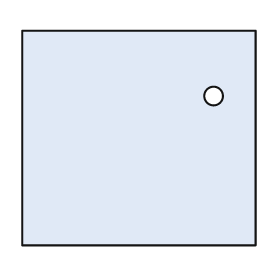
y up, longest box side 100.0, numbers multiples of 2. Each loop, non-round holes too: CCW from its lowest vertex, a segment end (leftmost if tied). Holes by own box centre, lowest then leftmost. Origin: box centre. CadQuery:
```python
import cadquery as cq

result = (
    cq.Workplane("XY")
    .moveTo(-50.0, -46.0)
    .lineTo(50.0, -46.0)
    .lineTo(50.0, 46.0)
    .lineTo(-50.0, 46.0)
    .close()
    .moveTo(32.0, 18.0)
    .circle(4.0)
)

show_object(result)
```